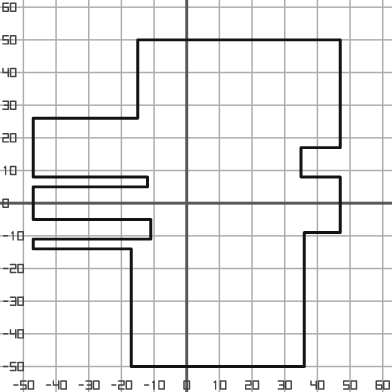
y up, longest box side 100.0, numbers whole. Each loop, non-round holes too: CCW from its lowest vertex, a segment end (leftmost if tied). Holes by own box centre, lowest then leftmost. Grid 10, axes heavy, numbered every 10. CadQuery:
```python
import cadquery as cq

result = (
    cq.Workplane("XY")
    .moveTo(-17.0, -50.0)
    .lineTo(36.0, -50.0)
    .lineTo(36.0, -9.0)
    .lineTo(47.0, -9.0)
    .lineTo(47.0, 8.0)
    .lineTo(35.0, 8.0)
    .lineTo(35.0, 17.0)
    .lineTo(47.0, 17.0)
    .lineTo(47.0, 50.0)
    .lineTo(-15.0, 50.0)
    .lineTo(-15.0, 26.0)
    .lineTo(-47.0, 26.0)
    .lineTo(-47.0, 8.0)
    .lineTo(-12.0, 8.0)
    .lineTo(-12.0, 5.0)
    .lineTo(-47.0, 5.0)
    .lineTo(-47.0, -5.0)
    .lineTo(-11.0, -5.0)
    .lineTo(-11.0, -11.0)
    .lineTo(-47.0, -11.0)
    .lineTo(-47.0, -14.0)
    .lineTo(-17.0, -14.0)
    .close()
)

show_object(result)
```